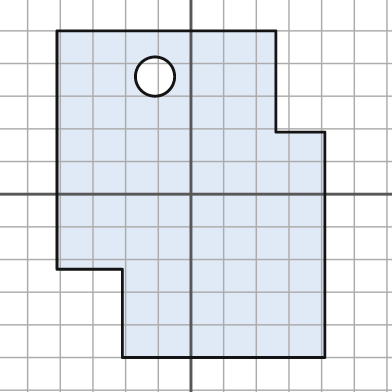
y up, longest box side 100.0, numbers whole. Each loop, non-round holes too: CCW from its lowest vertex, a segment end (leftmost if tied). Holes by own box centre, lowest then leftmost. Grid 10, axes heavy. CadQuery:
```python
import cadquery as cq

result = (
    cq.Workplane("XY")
    .moveTo(-21.0, -50.0)
    .lineTo(41.0, -50.0)
    .lineTo(41.0, 19.0)
    .lineTo(26.0, 19.0)
    .lineTo(26.0, 50.0)
    .lineTo(-41.0, 50.0)
    .lineTo(-41.0, -23.0)
    .lineTo(-21.0, -23.0)
    .close()
    .moveTo(-11.0, 36.0)
    .circle(6.0)
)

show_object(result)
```